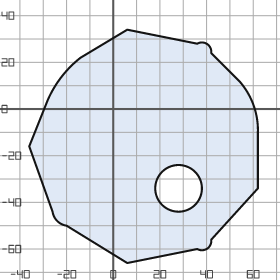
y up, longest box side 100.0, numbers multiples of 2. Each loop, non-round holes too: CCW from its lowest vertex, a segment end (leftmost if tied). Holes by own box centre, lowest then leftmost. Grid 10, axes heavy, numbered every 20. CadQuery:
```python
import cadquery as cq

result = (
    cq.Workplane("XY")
    .moveTo(6.0, -66.0)
    .lineTo(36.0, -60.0)
    .threePointArc((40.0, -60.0), (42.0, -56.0))
    .lineTo(62.0, -34.0)
    .lineTo(62.0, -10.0)
    .threePointArc((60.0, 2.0), (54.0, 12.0))
    .lineTo(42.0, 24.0)
    .threePointArc((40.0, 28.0), (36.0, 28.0))
    .lineTo(6.0, 34.0)
    .lineTo(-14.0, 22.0)
    .threePointArc((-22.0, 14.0), (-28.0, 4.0))
    .lineTo(-36.0, -16.0)
    .lineTo(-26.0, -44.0)
    .threePointArc((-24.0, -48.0), (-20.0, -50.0))
    .close()
    .moveTo(28.0, -34.0)
    .circle(10.0)
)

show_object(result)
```